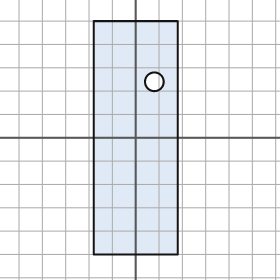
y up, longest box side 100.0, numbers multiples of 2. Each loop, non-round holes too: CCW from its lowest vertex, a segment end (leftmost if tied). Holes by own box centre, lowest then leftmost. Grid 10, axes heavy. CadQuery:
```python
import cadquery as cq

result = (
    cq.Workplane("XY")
    .moveTo(-18.0, -50.0)
    .lineTo(18.0, -50.0)
    .lineTo(18.0, 50.0)
    .lineTo(-18.0, 50.0)
    .close()
    .moveTo(8.0, 24.0)
    .circle(4.0)
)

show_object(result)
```